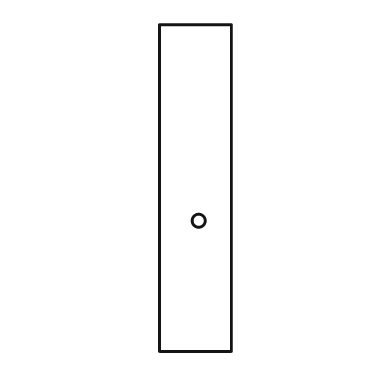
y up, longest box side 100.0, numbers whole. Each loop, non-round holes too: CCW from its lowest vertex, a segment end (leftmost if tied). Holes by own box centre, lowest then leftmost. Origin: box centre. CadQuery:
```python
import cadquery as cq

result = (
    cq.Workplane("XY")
    .moveTo(-11.0, -50.0)
    .lineTo(11.0, -50.0)
    .lineTo(11.0, 50.0)
    .lineTo(-11.0, 50.0)
    .close()
    .moveTo(1.0, -10.0)
    .circle(2.0)
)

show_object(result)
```